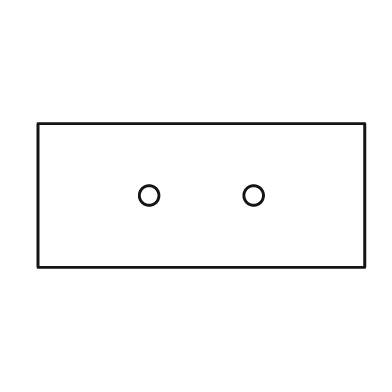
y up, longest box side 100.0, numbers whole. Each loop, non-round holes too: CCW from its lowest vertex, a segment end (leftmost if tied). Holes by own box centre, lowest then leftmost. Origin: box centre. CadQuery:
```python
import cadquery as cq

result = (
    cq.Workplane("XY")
    .moveTo(-50.0, -22.0)
    .lineTo(50.0, -22.0)
    .lineTo(50.0, 22.0)
    .lineTo(-50.0, 22.0)
    .close()
    .moveTo(-16.0, 0.0)
    .circle(3.0)
    .moveTo(16.0, 0.0)
    .circle(3.0)
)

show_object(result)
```